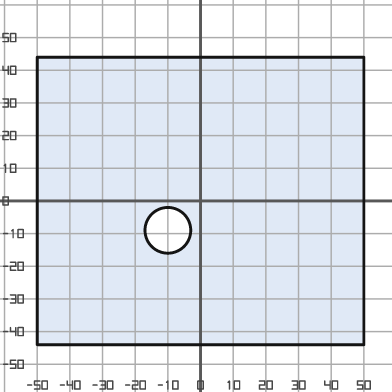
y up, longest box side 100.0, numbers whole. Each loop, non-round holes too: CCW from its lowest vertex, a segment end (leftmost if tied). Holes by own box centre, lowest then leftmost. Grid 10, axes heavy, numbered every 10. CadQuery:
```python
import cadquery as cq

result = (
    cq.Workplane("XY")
    .moveTo(-50.0, -44.0)
    .lineTo(50.0, -44.0)
    .lineTo(50.0, 44.0)
    .lineTo(-50.0, 44.0)
    .close()
    .moveTo(-10.0, -9.0)
    .circle(7.0)
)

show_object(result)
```